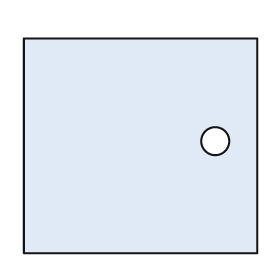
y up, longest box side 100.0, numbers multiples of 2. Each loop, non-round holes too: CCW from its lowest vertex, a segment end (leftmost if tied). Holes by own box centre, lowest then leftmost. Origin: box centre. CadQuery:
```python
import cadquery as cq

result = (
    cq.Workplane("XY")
    .moveTo(-50.0, -46.0)
    .lineTo(50.0, -46.0)
    .lineTo(50.0, 46.0)
    .lineTo(-50.0, 46.0)
    .close()
    .moveTo(32.0, 2.0)
    .circle(6.0)
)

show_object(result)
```